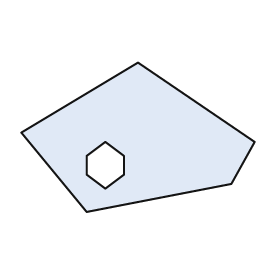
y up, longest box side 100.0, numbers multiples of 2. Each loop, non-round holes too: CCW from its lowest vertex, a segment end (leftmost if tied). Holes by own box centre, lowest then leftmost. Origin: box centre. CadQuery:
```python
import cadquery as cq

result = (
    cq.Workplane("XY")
    .moveTo(-22.0, -32.0)
    .lineTo(40.0, -20.0)
    .lineTo(50.0, -2.0)
    .lineTo(0.0, 32.0)
    .lineTo(-50.0, 2.0)
    .close()
    .moveTo(-14.0, -22.0)
    .lineTo(-6.0, -16.0)
    .lineTo(-6.0, -8.0)
    .lineTo(-14.0, -2.0)
    .lineTo(-22.0, -8.0)
    .lineTo(-22.0, -16.0)
    .close()
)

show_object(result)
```